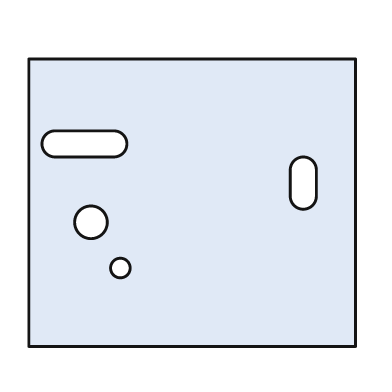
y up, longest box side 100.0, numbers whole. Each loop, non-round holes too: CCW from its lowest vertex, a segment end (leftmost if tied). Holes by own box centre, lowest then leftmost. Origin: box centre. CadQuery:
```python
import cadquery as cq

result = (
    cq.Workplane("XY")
    .moveTo(-50.0, -44.0)
    .lineTo(50.0, -44.0)
    .lineTo(50.0, 44.0)
    .lineTo(-50.0, 44.0)
    .close()
    .moveTo(-22.0, -20.0)
    .circle(3.0)
    .moveTo(-31.0, -6.0)
    .circle(5.0)
    .moveTo(30.0, 2.0)
    .threePointArc((34.0, -2.0), (38.0, 2.0))
    .lineTo(38.0, 10.0)
    .threePointArc((34.0, 14.0), (30.0, 10.0))
    .close()
    .moveTo(-42.0, 14.0)
    .lineTo(-24.0, 14.0)
    .threePointArc((-20.0, 18.0), (-24.0, 22.0))
    .lineTo(-42.0, 22.0)
    .threePointArc((-46.0, 18.0), (-42.0, 14.0))
    .close()
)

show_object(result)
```